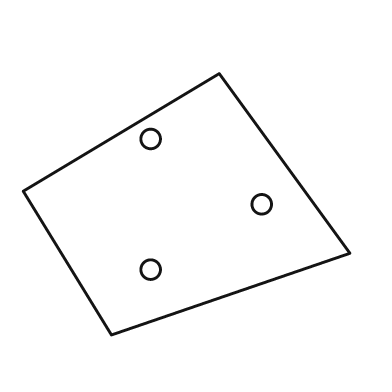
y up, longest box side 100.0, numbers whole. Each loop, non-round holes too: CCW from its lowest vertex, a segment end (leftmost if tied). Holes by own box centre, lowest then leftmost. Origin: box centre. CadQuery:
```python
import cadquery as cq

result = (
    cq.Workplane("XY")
    .moveTo(-23.0, -40.0)
    .lineTo(50.0, -15.0)
    .lineTo(10.0, 40.0)
    .lineTo(-50.0, 4.0)
    .close()
    .moveTo(-11.0, -20.0)
    .circle(3.0)
    .moveTo(23.0, 0.0)
    .circle(3.0)
    .moveTo(-11.0, 20.0)
    .circle(3.0)
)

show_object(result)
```